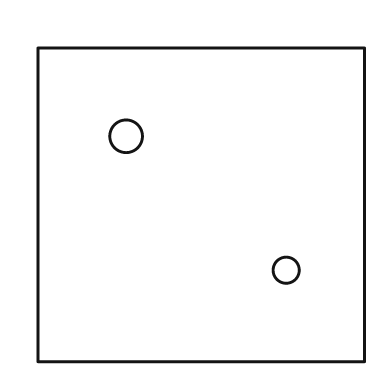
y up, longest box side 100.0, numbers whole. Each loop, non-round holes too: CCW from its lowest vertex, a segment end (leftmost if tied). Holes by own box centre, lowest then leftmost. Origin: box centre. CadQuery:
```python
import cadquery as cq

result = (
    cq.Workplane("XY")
    .moveTo(-50.0, -48.0)
    .lineTo(50.0, -48.0)
    .lineTo(50.0, 48.0)
    .lineTo(-50.0, 48.0)
    .close()
    .moveTo(26.0, -20.0)
    .circle(4.0)
    .moveTo(-23.0, 21.0)
    .circle(5.0)
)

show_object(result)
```